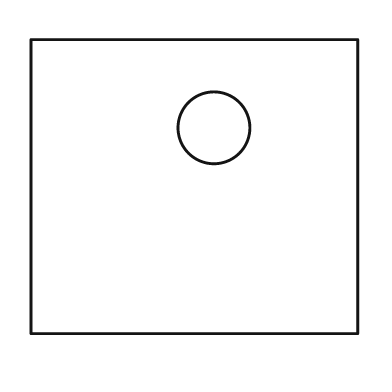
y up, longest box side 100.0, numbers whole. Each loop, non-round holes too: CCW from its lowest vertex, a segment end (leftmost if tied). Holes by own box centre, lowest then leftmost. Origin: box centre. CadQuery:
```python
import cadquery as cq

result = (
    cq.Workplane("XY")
    .moveTo(-50.0, -45.0)
    .lineTo(50.0, -45.0)
    .lineTo(50.0, 45.0)
    .lineTo(-50.0, 45.0)
    .close()
    .moveTo(6.0, 18.0)
    .circle(11.0)
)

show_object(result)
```